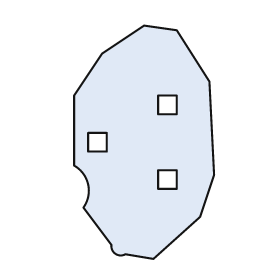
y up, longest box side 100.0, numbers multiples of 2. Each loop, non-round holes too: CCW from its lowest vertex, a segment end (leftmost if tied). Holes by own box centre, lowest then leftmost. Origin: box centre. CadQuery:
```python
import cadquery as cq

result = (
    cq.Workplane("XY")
    .moveTo(4.0, -50.0)
    .lineTo(24.0, -32.0)
    .lineTo(30.0, -14.0)
    .lineTo(28.0, 26.0)
    .lineTo(14.0, 48.0)
    .lineTo(0.0, 50.0)
    .lineTo(-18.0, 38.0)
    .lineTo(-30.0, 20.0)
    .lineTo(-30.0, -10.0)
    .threePointArc((-24.0, -18.0), (-26.0, -28.0))
    .lineTo(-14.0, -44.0)
    .threePointArc((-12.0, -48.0), (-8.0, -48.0))
    .close()
    .moveTo(6.0, -20.0)
    .lineTo(14.0, -20.0)
    .lineTo(14.0, -12.0)
    .lineTo(6.0, -12.0)
    .close()
    .moveTo(-24.0, -4.0)
    .lineTo(-16.0, -4.0)
    .lineTo(-16.0, 4.0)
    .lineTo(-24.0, 4.0)
    .close()
    .moveTo(6.0, 12.0)
    .lineTo(14.0, 12.0)
    .lineTo(14.0, 20.0)
    .lineTo(6.0, 20.0)
    .close()
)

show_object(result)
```